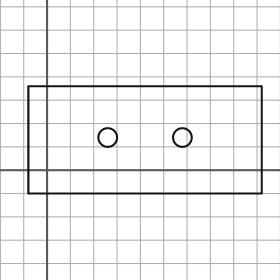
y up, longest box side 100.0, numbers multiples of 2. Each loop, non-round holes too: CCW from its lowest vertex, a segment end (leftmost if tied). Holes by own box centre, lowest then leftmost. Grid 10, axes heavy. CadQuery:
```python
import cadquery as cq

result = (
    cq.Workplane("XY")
    .moveTo(-8.0, -10.0)
    .lineTo(92.0, -10.0)
    .lineTo(92.0, 36.0)
    .lineTo(-8.0, 36.0)
    .close()
    .moveTo(26.0, 14.0)
    .circle(4.0)
    .moveTo(58.0, 14.0)
    .circle(4.0)
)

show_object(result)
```